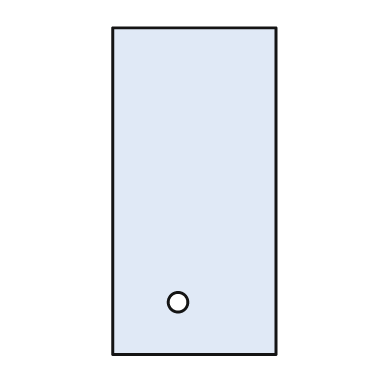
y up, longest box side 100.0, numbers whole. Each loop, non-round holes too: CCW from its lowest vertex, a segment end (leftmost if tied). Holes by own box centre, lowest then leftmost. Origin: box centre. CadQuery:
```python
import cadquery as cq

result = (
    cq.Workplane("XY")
    .moveTo(-25.0, -50.0)
    .lineTo(25.0, -50.0)
    .lineTo(25.0, 50.0)
    .lineTo(-25.0, 50.0)
    .close()
    .moveTo(-5.0, -34.0)
    .circle(3.0)
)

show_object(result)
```